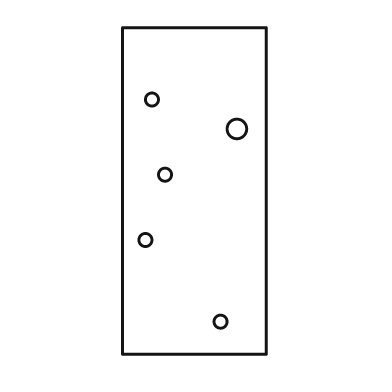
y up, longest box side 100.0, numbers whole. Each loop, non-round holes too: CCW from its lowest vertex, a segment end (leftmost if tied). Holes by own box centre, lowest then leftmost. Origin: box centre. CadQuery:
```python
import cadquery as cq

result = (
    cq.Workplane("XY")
    .moveTo(-22.0, -50.0)
    .lineTo(22.0, -50.0)
    .lineTo(22.0, 50.0)
    .lineTo(-22.0, 50.0)
    .close()
    .moveTo(8.0, -40.0)
    .circle(2.0)
    .moveTo(-15.0, -15.0)
    .circle(2.0)
    .moveTo(-9.0, 5.0)
    .circle(2.0)
    .moveTo(13.0, 19.0)
    .circle(3.0)
    .moveTo(-13.0, 28.0)
    .circle(2.0)
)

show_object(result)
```